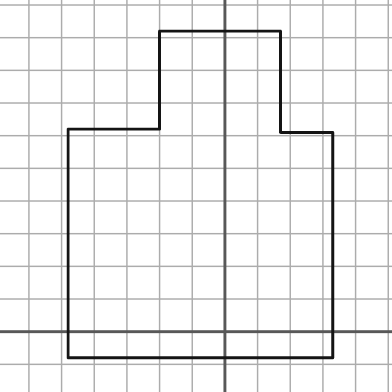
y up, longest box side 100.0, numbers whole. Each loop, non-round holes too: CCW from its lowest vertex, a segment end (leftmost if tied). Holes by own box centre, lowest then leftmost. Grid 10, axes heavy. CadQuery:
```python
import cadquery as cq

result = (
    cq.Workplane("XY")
    .moveTo(-48.0, -8.0)
    .lineTo(33.0, -8.0)
    .lineTo(33.0, 61.0)
    .lineTo(17.0, 61.0)
    .lineTo(17.0, 92.0)
    .lineTo(-20.0, 92.0)
    .lineTo(-20.0, 62.0)
    .lineTo(-48.0, 62.0)
    .close()
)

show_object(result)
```